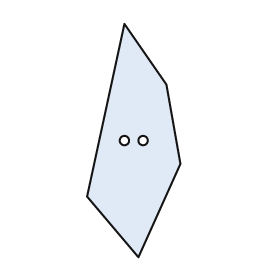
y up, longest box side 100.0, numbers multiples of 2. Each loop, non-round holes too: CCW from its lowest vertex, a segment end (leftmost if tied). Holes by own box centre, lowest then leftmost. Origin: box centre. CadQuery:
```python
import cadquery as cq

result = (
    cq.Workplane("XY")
    .moveTo(2.0, -50.0)
    .lineTo(20.0, -10.0)
    .lineTo(14.0, 24.0)
    .lineTo(-4.0, 50.0)
    .lineTo(-20.0, -24.0)
    .close()
    .moveTo(-4.0, 0.0)
    .circle(2.0)
    .moveTo(4.0, 0.0)
    .circle(2.0)
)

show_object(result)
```